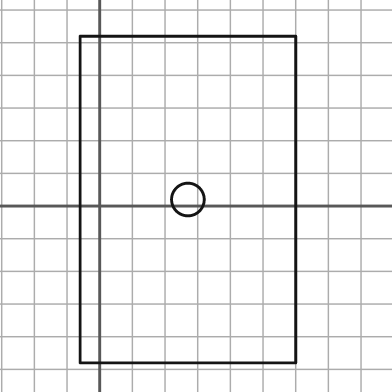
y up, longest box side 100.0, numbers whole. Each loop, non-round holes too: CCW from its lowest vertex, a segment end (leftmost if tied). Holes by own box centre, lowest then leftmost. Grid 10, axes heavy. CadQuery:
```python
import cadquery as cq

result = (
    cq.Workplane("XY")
    .moveTo(-6.0, -48.0)
    .lineTo(60.0, -48.0)
    .lineTo(60.0, 52.0)
    .lineTo(-6.0, 52.0)
    .close()
    .moveTo(27.0, 2.0)
    .circle(5.0)
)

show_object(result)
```